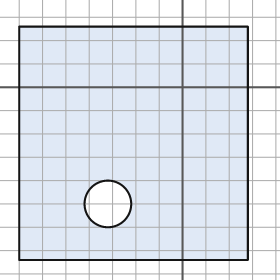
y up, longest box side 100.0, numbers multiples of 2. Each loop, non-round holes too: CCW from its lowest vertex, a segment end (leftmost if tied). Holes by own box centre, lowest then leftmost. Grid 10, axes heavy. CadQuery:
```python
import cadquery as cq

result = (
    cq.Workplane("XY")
    .moveTo(-70.0, -74.0)
    .lineTo(28.0, -74.0)
    .lineTo(28.0, 26.0)
    .lineTo(-70.0, 26.0)
    .close()
    .moveTo(-32.0, -50.0)
    .circle(10.0)
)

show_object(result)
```